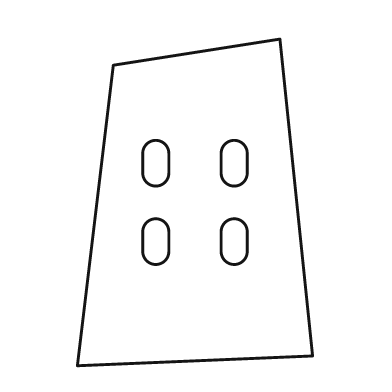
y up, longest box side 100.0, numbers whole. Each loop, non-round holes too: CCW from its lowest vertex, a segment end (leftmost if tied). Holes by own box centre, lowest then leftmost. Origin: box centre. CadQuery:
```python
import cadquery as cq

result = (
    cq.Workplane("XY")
    .moveTo(-36.0, -50.0)
    .lineTo(36.0, -47.0)
    .lineTo(26.0, 50.0)
    .lineTo(-25.0, 42.0)
    .close()
    .moveTo(-16.0, -15.0)
    .threePointArc((-12.0, -19.0), (-8.0, -15.0))
    .lineTo(-8.0, -9.0)
    .threePointArc((-12.0, -5.0), (-16.0, -9.0))
    .close()
    .moveTo(8.0, -15.0)
    .threePointArc((12.0, -19.0), (16.0, -15.0))
    .lineTo(16.0, -9.0)
    .threePointArc((12.0, -5.0), (8.0, -9.0))
    .close()
    .moveTo(-16.0, 9.0)
    .threePointArc((-12.0, 5.0), (-8.0, 9.0))
    .lineTo(-8.0, 15.0)
    .threePointArc((-12.0, 19.0), (-16.0, 15.0))
    .close()
    .moveTo(8.0, 9.0)
    .threePointArc((12.0, 5.0), (16.0, 9.0))
    .lineTo(16.0, 15.0)
    .threePointArc((12.0, 19.0), (8.0, 15.0))
    .close()
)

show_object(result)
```